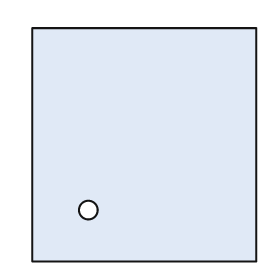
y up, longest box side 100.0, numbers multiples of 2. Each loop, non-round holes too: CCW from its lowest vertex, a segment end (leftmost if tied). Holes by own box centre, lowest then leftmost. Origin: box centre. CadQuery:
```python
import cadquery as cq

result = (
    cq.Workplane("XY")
    .moveTo(-48.0, -50.0)
    .lineTo(48.0, -50.0)
    .lineTo(48.0, 50.0)
    .lineTo(-48.0, 50.0)
    .close()
    .moveTo(-24.0, -28.0)
    .circle(4.0)
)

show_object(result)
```